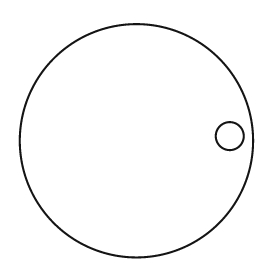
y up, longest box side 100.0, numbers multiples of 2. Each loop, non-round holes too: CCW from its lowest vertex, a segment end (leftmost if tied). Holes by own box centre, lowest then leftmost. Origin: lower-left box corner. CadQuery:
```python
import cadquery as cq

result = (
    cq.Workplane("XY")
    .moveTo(50.0, 50.0)
    .circle(50.0)
    .moveTo(90.0, 52.0)
    .circle(6.0)
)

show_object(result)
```